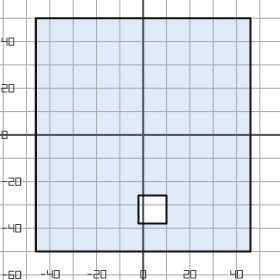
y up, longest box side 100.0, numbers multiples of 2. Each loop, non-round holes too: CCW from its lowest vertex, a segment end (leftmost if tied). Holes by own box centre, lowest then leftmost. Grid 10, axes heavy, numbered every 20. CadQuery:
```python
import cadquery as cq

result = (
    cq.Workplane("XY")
    .moveTo(-46.0, -50.0)
    .lineTo(46.0, -50.0)
    .lineTo(46.0, 50.0)
    .lineTo(-46.0, 50.0)
    .close()
    .moveTo(-2.0, -38.0)
    .lineTo(10.0, -38.0)
    .lineTo(10.0, -26.0)
    .lineTo(-2.0, -26.0)
    .close()
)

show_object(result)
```